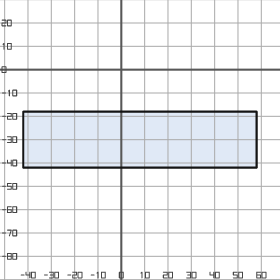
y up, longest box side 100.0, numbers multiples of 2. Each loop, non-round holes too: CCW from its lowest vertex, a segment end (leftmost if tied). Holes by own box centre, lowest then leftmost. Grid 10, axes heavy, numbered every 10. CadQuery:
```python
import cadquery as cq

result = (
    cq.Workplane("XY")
    .moveTo(-42.0, -42.0)
    .lineTo(58.0, -42.0)
    .lineTo(58.0, -18.0)
    .lineTo(-42.0, -18.0)
    .close()
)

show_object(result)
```